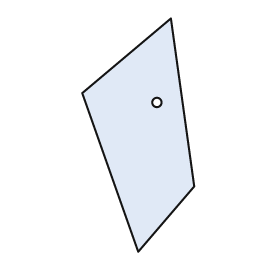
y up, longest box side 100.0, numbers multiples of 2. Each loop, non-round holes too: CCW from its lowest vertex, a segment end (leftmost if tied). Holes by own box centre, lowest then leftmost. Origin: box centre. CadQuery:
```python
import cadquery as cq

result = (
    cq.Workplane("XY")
    .moveTo(0.0, -50.0)
    .lineTo(24.0, -22.0)
    .lineTo(14.0, 50.0)
    .lineTo(-24.0, 18.0)
    .close()
    .moveTo(8.0, 14.0)
    .circle(2.0)
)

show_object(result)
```